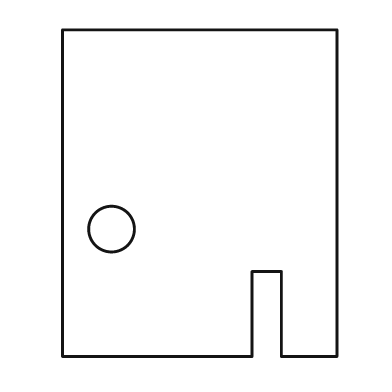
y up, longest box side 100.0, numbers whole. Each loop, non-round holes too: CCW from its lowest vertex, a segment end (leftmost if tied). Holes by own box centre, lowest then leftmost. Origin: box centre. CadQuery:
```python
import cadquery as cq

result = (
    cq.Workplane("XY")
    .moveTo(-42.0, -50.0)
    .lineTo(16.0, -50.0)
    .lineTo(16.0, -24.0)
    .lineTo(25.0, -24.0)
    .lineTo(25.0, -50.0)
    .lineTo(42.0, -50.0)
    .lineTo(42.0, 50.0)
    .lineTo(-42.0, 50.0)
    .close()
    .moveTo(-27.0, -11.0)
    .circle(7.0)
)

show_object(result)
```